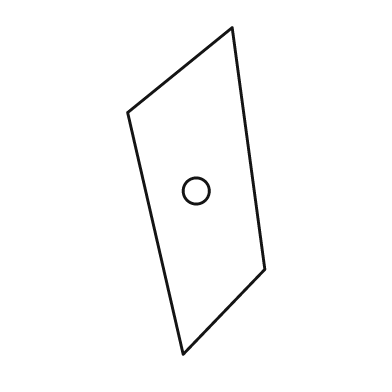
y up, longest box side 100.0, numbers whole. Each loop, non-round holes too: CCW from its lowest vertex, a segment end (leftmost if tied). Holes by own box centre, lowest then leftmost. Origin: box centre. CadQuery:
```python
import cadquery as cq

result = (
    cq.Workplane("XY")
    .moveTo(-4.0, -50.0)
    .lineTo(21.0, -24.0)
    .lineTo(11.0, 50.0)
    .lineTo(-21.0, 24.0)
    .close()
    .moveTo(0.0, 0.0)
    .circle(4.0)
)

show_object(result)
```